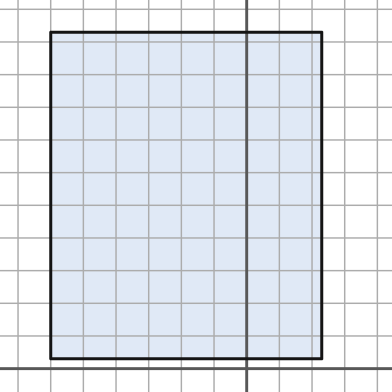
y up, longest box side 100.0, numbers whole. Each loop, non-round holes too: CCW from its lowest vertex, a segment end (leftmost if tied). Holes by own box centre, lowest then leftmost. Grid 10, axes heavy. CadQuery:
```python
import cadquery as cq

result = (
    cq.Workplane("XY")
    .moveTo(-60.0, 3.0)
    .lineTo(23.0, 3.0)
    .lineTo(23.0, 103.0)
    .lineTo(-60.0, 103.0)
    .close()
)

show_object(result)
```